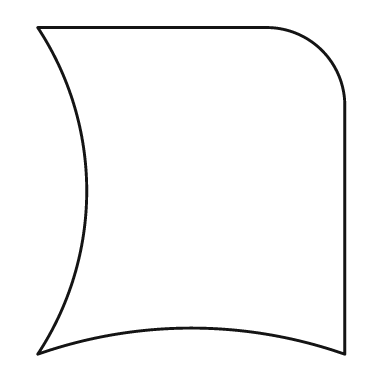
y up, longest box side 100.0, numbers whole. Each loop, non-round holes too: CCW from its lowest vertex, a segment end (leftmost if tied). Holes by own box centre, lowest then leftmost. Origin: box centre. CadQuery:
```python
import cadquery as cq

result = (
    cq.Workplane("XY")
    .moveTo(-47.0, -50.0)
    .threePointArc((0.0, -42.0), (47.0, -50.0))
    .lineTo(47.0, 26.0)
    .threePointArc((40.0, 43.0), (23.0, 50.0))
    .lineTo(-47.0, 50.0)
    .threePointArc((-32.0, 0.0), (-47.0, -50.0))
    .close()
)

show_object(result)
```